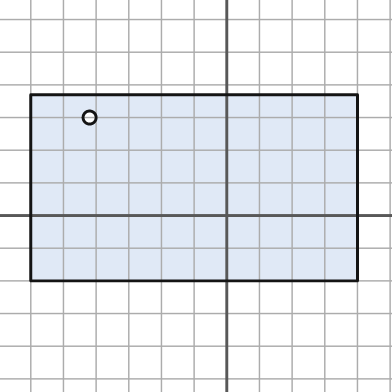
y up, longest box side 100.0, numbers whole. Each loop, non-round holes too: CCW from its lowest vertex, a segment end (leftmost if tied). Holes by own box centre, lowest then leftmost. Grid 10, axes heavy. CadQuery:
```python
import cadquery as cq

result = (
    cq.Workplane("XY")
    .moveTo(-60.0, -20.0)
    .lineTo(40.0, -20.0)
    .lineTo(40.0, 37.0)
    .lineTo(-60.0, 37.0)
    .close()
    .moveTo(-42.0, 30.0)
    .circle(2.0)
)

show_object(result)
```